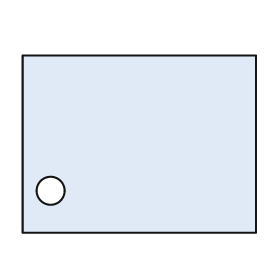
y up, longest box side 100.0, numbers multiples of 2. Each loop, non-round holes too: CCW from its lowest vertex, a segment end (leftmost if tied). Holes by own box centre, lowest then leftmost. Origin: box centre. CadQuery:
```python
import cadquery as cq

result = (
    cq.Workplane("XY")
    .moveTo(-50.0, -38.0)
    .lineTo(50.0, -38.0)
    .lineTo(50.0, 38.0)
    .lineTo(-50.0, 38.0)
    .close()
    .moveTo(-38.0, -20.0)
    .circle(6.0)
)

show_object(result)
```